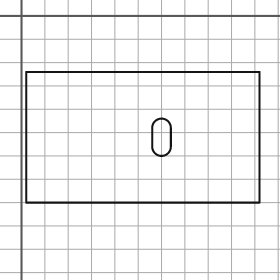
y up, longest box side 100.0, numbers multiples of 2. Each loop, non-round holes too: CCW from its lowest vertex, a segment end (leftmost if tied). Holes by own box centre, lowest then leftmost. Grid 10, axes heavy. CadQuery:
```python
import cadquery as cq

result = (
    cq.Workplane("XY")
    .moveTo(2.0, -80.0)
    .lineTo(102.0, -80.0)
    .lineTo(102.0, -24.0)
    .lineTo(2.0, -24.0)
    .close()
    .moveTo(56.0, -56.0)
    .threePointArc((60.0, -60.0), (64.0, -56.0))
    .lineTo(64.0, -48.0)
    .threePointArc((60.0, -44.0), (56.0, -48.0))
    .close()
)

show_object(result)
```